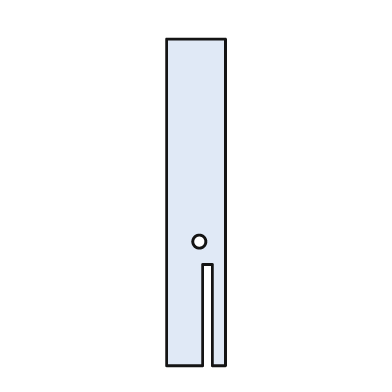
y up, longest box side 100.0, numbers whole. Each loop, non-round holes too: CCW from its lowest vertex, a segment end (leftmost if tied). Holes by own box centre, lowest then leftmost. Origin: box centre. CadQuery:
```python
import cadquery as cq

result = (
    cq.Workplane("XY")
    .moveTo(-9.0, -50.0)
    .lineTo(2.0, -50.0)
    .lineTo(2.0, -19.0)
    .lineTo(5.0, -19.0)
    .lineTo(5.0, -50.0)
    .lineTo(9.0, -50.0)
    .lineTo(9.0, 50.0)
    .lineTo(-9.0, 50.0)
    .close()
    .moveTo(1.0, -12.0)
    .circle(2.0)
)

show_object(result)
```